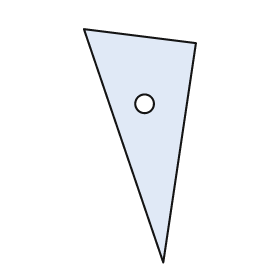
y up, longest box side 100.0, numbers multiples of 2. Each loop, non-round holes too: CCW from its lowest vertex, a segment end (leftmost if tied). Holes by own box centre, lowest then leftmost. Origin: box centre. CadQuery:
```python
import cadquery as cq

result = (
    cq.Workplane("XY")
    .moveTo(10.0, -50.0)
    .lineTo(24.0, 44.0)
    .lineTo(-24.0, 50.0)
    .close()
    .moveTo(2.0, 18.0)
    .circle(4.0)
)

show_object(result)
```